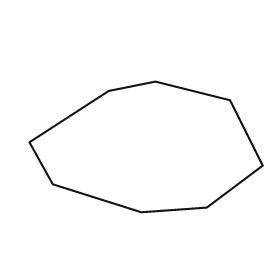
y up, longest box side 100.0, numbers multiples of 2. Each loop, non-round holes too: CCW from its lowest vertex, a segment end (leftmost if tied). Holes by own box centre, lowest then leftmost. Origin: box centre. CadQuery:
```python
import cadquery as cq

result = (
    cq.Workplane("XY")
    .moveTo(-2.0, -28.0)
    .lineTo(26.0, -26.0)
    .lineTo(50.0, -8.0)
    .lineTo(36.0, 20.0)
    .lineTo(4.0, 28.0)
    .lineTo(-16.0, 24.0)
    .lineTo(-50.0, 2.0)
    .lineTo(-40.0, -16.0)
    .close()
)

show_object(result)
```